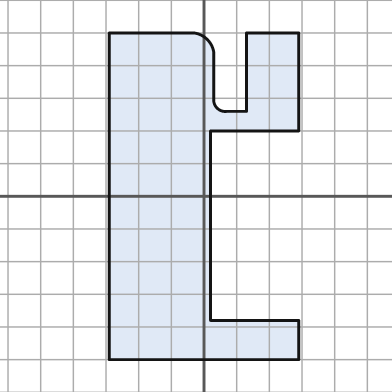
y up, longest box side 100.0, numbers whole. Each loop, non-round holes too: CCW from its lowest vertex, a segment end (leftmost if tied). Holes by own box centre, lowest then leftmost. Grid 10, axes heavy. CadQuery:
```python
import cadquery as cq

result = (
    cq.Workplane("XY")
    .moveTo(-29.0, -50.0)
    .lineTo(29.0, -50.0)
    .lineTo(29.0, -38.0)
    .lineTo(2.0, -38.0)
    .lineTo(2.0, 20.0)
    .lineTo(29.0, 20.0)
    .lineTo(29.0, 50.0)
    .lineTo(13.0, 50.0)
    .lineTo(13.0, 26.0)
    .lineTo(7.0, 26.0)
    .threePointArc((4.0, 27.0), (3.0, 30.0))
    .lineTo(3.0, 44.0)
    .threePointArc((1.0, 48.0), (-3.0, 50.0))
    .lineTo(-29.0, 50.0)
    .close()
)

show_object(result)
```